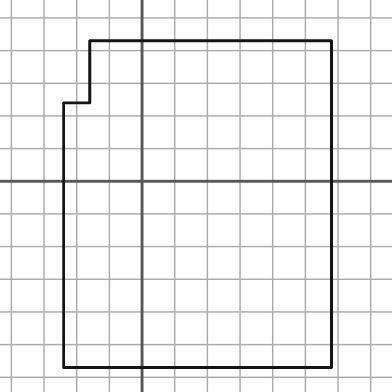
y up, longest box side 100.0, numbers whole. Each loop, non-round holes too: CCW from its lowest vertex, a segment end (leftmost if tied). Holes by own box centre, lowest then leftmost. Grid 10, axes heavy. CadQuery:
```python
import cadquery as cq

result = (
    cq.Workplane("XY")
    .moveTo(-24.0, -57.0)
    .lineTo(58.0, -57.0)
    .lineTo(58.0, 43.0)
    .lineTo(-16.0, 43.0)
    .lineTo(-16.0, 24.0)
    .lineTo(-24.0, 24.0)
    .close()
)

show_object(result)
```